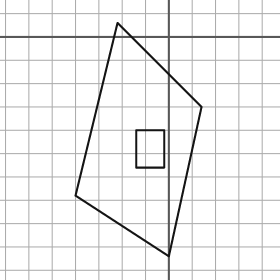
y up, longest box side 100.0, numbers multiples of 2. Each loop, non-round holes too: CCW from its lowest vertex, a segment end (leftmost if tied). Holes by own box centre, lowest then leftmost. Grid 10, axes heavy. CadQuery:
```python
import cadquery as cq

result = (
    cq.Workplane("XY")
    .moveTo(0.0, -94.0)
    .lineTo(14.0, -30.0)
    .lineTo(-22.0, 6.0)
    .lineTo(-40.0, -68.0)
    .close()
    .moveTo(-14.0, -56.0)
    .lineTo(-2.0, -56.0)
    .lineTo(-2.0, -40.0)
    .lineTo(-14.0, -40.0)
    .close()
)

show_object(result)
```